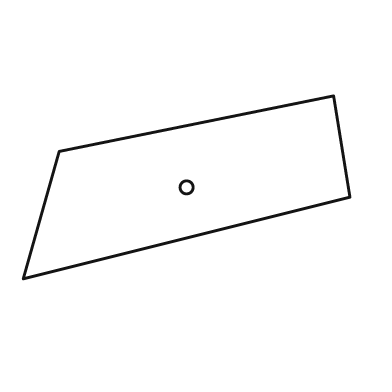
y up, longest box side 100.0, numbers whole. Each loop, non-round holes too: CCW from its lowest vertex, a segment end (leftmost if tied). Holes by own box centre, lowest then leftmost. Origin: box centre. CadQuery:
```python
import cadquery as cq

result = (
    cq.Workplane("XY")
    .moveTo(-50.0, -28.0)
    .lineTo(50.0, -3.0)
    .lineTo(45.0, 28.0)
    .lineTo(-39.0, 11.0)
    .close()
    .moveTo(0.0, 0.0)
    .circle(2.0)
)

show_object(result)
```